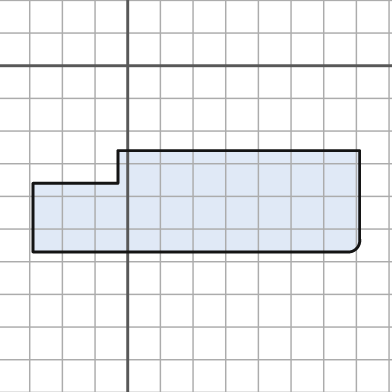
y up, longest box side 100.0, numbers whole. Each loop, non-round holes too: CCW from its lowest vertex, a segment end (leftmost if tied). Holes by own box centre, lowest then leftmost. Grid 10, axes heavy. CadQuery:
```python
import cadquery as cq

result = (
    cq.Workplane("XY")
    .moveTo(-29.0, -57.0)
    .lineTo(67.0, -57.0)
    .threePointArc((70.0, -56.0), (71.0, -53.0))
    .lineTo(71.0, -26.0)
    .lineTo(-3.0, -26.0)
    .lineTo(-3.0, -36.0)
    .lineTo(-29.0, -36.0)
    .close()
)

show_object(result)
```